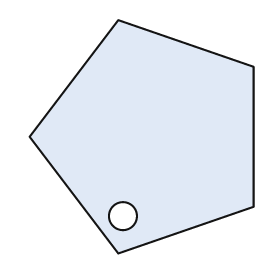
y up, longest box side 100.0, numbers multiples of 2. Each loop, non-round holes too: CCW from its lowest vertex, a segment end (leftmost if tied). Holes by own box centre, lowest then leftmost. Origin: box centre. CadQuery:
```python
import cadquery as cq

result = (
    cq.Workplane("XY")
    .moveTo(-10.0, -50.0)
    .lineTo(48.0, -30.0)
    .lineTo(48.0, 30.0)
    .lineTo(-10.0, 50.0)
    .lineTo(-48.0, 0.0)
    .close()
    .moveTo(-8.0, -34.0)
    .circle(6.0)
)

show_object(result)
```